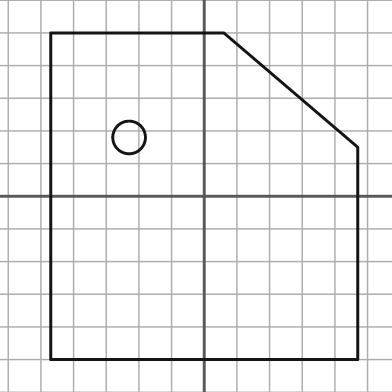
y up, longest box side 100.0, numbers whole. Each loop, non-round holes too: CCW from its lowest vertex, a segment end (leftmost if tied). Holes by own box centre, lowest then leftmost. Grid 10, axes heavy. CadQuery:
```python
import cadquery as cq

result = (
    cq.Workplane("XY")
    .moveTo(-47.0, -50.0)
    .lineTo(47.0, -50.0)
    .lineTo(47.0, 15.0)
    .lineTo(6.0, 50.0)
    .lineTo(-47.0, 50.0)
    .close()
    .moveTo(-23.0, 18.0)
    .circle(5.0)
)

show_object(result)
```